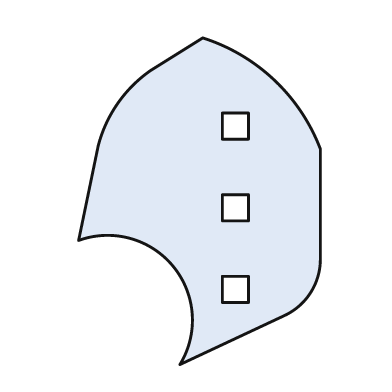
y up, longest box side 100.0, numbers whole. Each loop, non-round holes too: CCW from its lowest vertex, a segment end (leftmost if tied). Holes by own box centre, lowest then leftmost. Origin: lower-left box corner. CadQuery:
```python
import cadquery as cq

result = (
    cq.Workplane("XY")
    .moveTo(31.0, 0.0)
    .lineTo(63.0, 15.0)
    .threePointArc((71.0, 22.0), (74.0, 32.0))
    .lineTo(74.0, 66.0)
    .threePointArc((60.0, 87.0), (38.0, 100.0))
    .lineTo(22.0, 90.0)
    .threePointArc((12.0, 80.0), (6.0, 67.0))
    .lineTo(0.0, 38.0)
    .threePointArc((29.0, 30.0), (31.0, 0.0))
    .close()
    .moveTo(44.0, 19.0)
    .lineTo(52.0, 19.0)
    .lineTo(52.0, 27.0)
    .lineTo(44.0, 27.0)
    .close()
    .moveTo(44.0, 44.0)
    .lineTo(52.0, 44.0)
    .lineTo(52.0, 52.0)
    .lineTo(44.0, 52.0)
    .close()
    .moveTo(44.0, 69.0)
    .lineTo(52.0, 69.0)
    .lineTo(52.0, 77.0)
    .lineTo(44.0, 77.0)
    .close()
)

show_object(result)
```